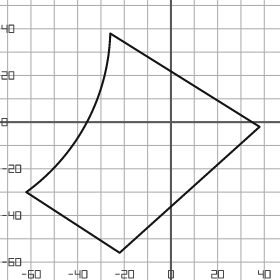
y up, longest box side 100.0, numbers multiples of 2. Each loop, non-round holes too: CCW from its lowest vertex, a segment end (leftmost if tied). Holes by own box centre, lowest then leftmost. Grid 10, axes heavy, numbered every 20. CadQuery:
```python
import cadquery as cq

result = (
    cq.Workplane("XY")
    .moveTo(-22.0, -56.0)
    .lineTo(38.0, -2.0)
    .lineTo(-26.0, 38.0)
    .threePointArc((-36.0, 0.0), (-62.0, -30.0))
    .close()
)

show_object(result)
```